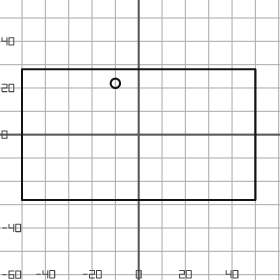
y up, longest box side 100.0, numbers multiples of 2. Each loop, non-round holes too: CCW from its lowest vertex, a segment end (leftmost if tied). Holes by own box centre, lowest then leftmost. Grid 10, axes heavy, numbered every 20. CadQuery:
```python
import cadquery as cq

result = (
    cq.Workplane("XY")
    .moveTo(-50.0, -28.0)
    .lineTo(50.0, -28.0)
    .lineTo(50.0, 28.0)
    .lineTo(-50.0, 28.0)
    .close()
    .moveTo(-10.0, 22.0)
    .circle(2.0)
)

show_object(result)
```